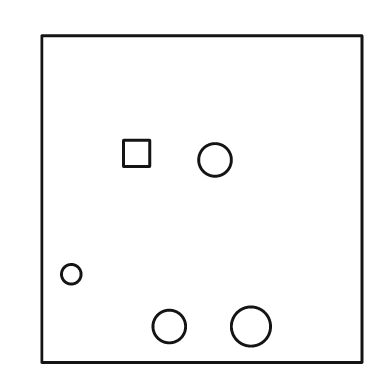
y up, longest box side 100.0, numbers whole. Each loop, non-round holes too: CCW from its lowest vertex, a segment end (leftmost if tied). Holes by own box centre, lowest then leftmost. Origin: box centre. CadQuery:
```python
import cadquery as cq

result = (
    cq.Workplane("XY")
    .moveTo(-49.0, -50.0)
    .lineTo(49.0, -50.0)
    .lineTo(49.0, 50.0)
    .lineTo(-49.0, 50.0)
    .close()
    .moveTo(-10.0, -39.0)
    .circle(5.0)
    .moveTo(15.0, -39.0)
    .circle(6.0)
    .moveTo(-40.0, -23.0)
    .circle(3.0)
    .moveTo(4.0, 12.0)
    .circle(5.0)
    .moveTo(-24.0, 10.0)
    .lineTo(-16.0, 10.0)
    .lineTo(-16.0, 18.0)
    .lineTo(-24.0, 18.0)
    .close()
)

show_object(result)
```